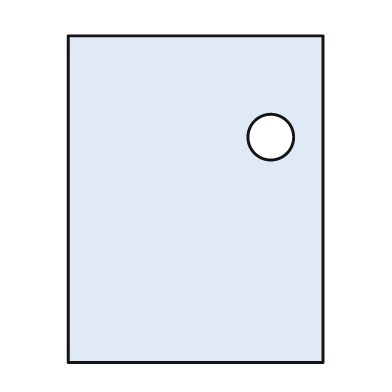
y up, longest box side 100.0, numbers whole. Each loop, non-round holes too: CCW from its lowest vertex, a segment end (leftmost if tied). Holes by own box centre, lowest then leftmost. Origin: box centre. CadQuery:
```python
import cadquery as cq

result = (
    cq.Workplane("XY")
    .moveTo(-39.0, -50.0)
    .lineTo(39.0, -50.0)
    .lineTo(39.0, 50.0)
    .lineTo(-39.0, 50.0)
    .close()
    .moveTo(23.0, 19.0)
    .circle(7.0)
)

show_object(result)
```